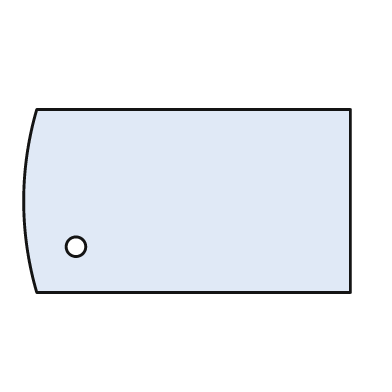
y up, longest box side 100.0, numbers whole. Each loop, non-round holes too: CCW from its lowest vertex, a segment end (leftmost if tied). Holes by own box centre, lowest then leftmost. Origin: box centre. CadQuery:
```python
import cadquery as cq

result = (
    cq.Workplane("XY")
    .moveTo(-46.0, -28.0)
    .lineTo(50.0, -28.0)
    .lineTo(50.0, 28.0)
    .lineTo(-46.0, 28.0)
    .threePointArc((-50.0, 0.0), (-46.0, -28.0))
    .close()
    .moveTo(-34.0, -14.0)
    .circle(3.0)
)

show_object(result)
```